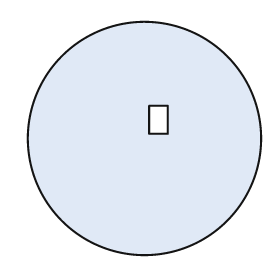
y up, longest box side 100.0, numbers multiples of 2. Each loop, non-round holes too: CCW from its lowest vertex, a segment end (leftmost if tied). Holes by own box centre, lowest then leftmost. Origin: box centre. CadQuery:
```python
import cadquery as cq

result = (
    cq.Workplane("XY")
    .moveTo(0.0, 0.0)
    .circle(50.0)
    .moveTo(2.0, 2.0)
    .lineTo(10.0, 2.0)
    .lineTo(10.0, 14.0)
    .lineTo(2.0, 14.0)
    .close()
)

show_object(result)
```